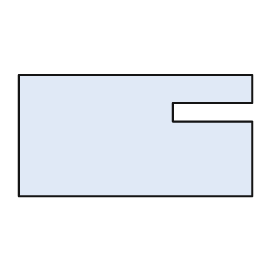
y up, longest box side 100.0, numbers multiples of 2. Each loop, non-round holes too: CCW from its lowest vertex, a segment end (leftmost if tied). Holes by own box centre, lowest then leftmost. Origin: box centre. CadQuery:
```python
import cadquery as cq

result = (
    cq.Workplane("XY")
    .moveTo(-50.0, -26.0)
    .lineTo(50.0, -26.0)
    .lineTo(50.0, 6.0)
    .lineTo(16.0, 6.0)
    .lineTo(16.0, 14.0)
    .lineTo(50.0, 14.0)
    .lineTo(50.0, 26.0)
    .lineTo(-50.0, 26.0)
    .close()
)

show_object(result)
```